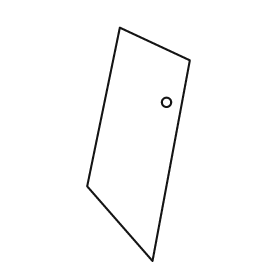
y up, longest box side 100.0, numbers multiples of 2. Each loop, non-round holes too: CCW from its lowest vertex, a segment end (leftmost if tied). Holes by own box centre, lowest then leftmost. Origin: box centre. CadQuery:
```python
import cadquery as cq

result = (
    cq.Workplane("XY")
    .moveTo(6.0, -50.0)
    .lineTo(22.0, 36.0)
    .lineTo(-8.0, 50.0)
    .lineTo(-22.0, -18.0)
    .close()
    .moveTo(12.0, 18.0)
    .circle(2.0)
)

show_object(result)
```